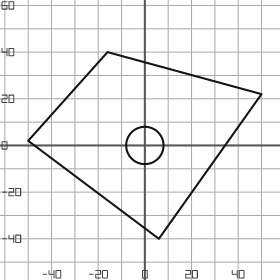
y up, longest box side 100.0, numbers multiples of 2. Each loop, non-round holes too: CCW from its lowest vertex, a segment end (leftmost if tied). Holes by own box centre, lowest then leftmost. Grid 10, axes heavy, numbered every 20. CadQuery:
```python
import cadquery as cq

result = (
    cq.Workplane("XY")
    .moveTo(6.0, -40.0)
    .lineTo(50.0, 22.0)
    .lineTo(-16.0, 40.0)
    .lineTo(-50.0, 2.0)
    .close()
    .moveTo(0.0, 0.0)
    .circle(8.0)
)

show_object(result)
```